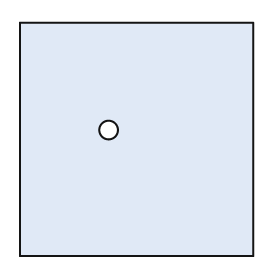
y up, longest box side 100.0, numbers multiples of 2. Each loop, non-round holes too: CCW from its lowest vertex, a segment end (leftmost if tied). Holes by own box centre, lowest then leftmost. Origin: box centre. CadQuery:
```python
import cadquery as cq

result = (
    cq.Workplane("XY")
    .moveTo(-50.0, -50.0)
    .lineTo(50.0, -50.0)
    .lineTo(50.0, 50.0)
    .lineTo(-50.0, 50.0)
    .close()
    .moveTo(-12.0, 4.0)
    .circle(4.0)
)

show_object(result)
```